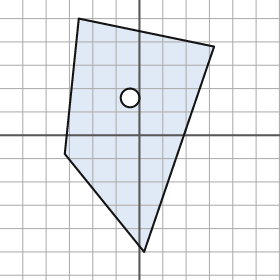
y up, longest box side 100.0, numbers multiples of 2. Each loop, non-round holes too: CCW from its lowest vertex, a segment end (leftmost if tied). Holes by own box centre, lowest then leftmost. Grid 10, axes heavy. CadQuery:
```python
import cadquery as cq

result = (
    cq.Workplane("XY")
    .moveTo(2.0, -50.0)
    .lineTo(32.0, 38.0)
    .lineTo(-26.0, 50.0)
    .lineTo(-32.0, -8.0)
    .close()
    .moveTo(-4.0, 16.0)
    .circle(4.0)
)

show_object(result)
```